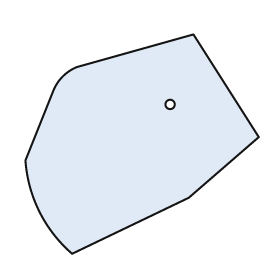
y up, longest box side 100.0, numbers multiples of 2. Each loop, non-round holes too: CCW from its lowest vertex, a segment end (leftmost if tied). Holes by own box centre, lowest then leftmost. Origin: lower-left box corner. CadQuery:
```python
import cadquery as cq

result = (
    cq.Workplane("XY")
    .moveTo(20.0, 0.0)
    .lineTo(70.0, 24.0)
    .lineTo(100.0, 50.0)
    .lineTo(72.0, 94.0)
    .lineTo(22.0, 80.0)
    .threePointArc((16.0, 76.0), (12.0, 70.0))
    .lineTo(0.0, 40.0)
    .threePointArc((6.0, 18.0), (20.0, 0.0))
    .close()
    .moveTo(62.0, 64.0)
    .circle(2.0)
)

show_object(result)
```